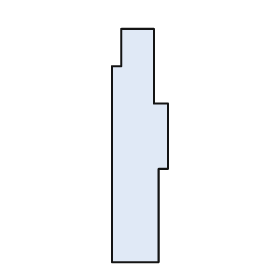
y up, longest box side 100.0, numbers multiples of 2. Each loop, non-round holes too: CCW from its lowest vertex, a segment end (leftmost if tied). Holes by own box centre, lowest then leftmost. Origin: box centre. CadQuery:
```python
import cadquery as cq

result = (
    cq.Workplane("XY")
    .moveTo(-12.0, -50.0)
    .lineTo(8.0, -50.0)
    .lineTo(8.0, -10.0)
    .lineTo(12.0, -10.0)
    .lineTo(12.0, 18.0)
    .lineTo(6.0, 18.0)
    .lineTo(6.0, 50.0)
    .lineTo(-8.0, 50.0)
    .lineTo(-8.0, 34.0)
    .lineTo(-12.0, 34.0)
    .close()
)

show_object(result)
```